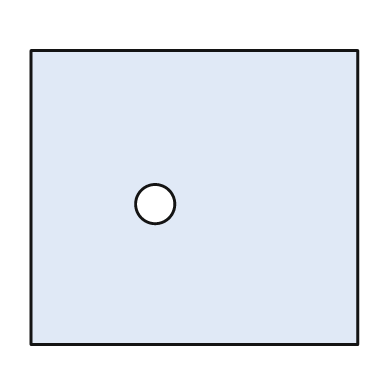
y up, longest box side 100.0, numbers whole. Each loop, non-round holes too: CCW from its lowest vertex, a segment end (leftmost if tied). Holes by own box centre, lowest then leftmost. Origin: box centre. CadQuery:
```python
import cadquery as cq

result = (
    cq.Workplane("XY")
    .moveTo(-50.0, -45.0)
    .lineTo(50.0, -45.0)
    .lineTo(50.0, 45.0)
    .lineTo(-50.0, 45.0)
    .close()
    .moveTo(-12.0, -2.0)
    .circle(6.0)
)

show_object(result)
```